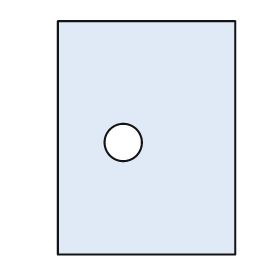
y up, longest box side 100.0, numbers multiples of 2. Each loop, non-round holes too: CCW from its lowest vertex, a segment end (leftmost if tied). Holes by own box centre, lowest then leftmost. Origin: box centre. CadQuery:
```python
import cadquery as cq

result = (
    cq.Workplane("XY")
    .moveTo(-38.0, -50.0)
    .lineTo(38.0, -50.0)
    .lineTo(38.0, 50.0)
    .lineTo(-38.0, 50.0)
    .close()
    .moveTo(-10.0, -2.0)
    .circle(8.0)
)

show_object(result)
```